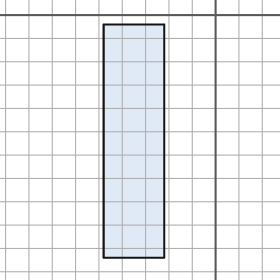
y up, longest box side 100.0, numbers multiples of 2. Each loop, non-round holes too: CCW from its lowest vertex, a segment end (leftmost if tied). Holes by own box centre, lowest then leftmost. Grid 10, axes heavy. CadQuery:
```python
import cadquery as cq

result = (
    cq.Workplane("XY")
    .moveTo(-48.0, -104.0)
    .lineTo(-22.0, -104.0)
    .lineTo(-22.0, -4.0)
    .lineTo(-48.0, -4.0)
    .close()
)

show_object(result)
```